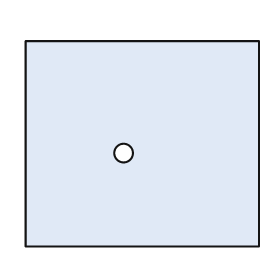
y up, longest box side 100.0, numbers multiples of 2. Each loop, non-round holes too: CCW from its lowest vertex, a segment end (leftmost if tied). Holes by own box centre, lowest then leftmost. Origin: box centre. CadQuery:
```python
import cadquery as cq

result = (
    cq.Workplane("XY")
    .moveTo(-50.0, -44.0)
    .lineTo(50.0, -44.0)
    .lineTo(50.0, 44.0)
    .lineTo(-50.0, 44.0)
    .close()
    .moveTo(-8.0, -4.0)
    .circle(4.0)
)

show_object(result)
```